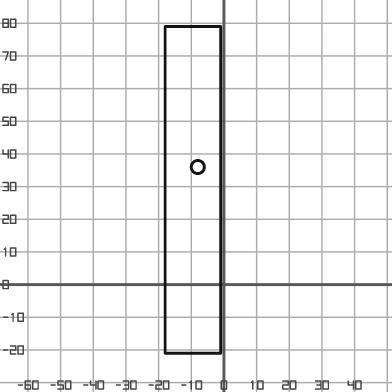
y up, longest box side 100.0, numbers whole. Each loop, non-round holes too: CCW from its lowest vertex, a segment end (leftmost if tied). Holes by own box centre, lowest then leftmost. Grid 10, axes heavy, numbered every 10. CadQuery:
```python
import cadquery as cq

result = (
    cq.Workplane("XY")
    .moveTo(-18.0, -21.0)
    .lineTo(-1.0, -21.0)
    .lineTo(-1.0, 79.0)
    .lineTo(-18.0, 79.0)
    .close()
    .moveTo(-8.0, 36.0)
    .circle(2.0)
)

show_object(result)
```